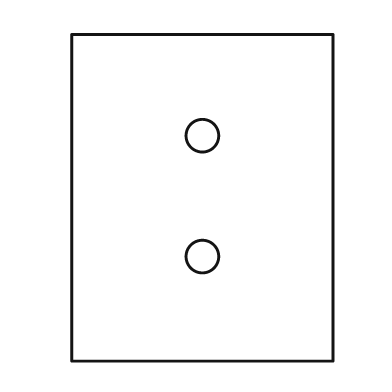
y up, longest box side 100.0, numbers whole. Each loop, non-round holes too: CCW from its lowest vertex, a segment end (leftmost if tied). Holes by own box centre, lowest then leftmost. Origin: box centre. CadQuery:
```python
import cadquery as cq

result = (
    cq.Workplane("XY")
    .moveTo(-40.0, -50.0)
    .lineTo(40.0, -50.0)
    .lineTo(40.0, 50.0)
    .lineTo(-40.0, 50.0)
    .close()
    .moveTo(0.0, -18.0)
    .circle(5.0)
    .moveTo(0.0, 19.0)
    .circle(5.0)
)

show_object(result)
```